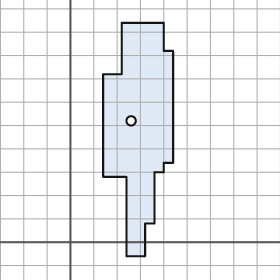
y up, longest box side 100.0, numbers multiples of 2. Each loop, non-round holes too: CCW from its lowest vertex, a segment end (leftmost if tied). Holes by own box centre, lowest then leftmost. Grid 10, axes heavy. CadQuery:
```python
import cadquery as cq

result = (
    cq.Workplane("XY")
    .moveTo(24.0, -6.0)
    .lineTo(32.0, -6.0)
    .lineTo(32.0, 8.0)
    .lineTo(36.0, 8.0)
    .lineTo(36.0, 30.0)
    .lineTo(40.0, 30.0)
    .lineTo(40.0, 34.0)
    .lineTo(44.0, 34.0)
    .lineTo(44.0, 82.0)
    .lineTo(40.0, 82.0)
    .lineTo(40.0, 94.0)
    .lineTo(22.0, 94.0)
    .lineTo(22.0, 72.0)
    .lineTo(14.0, 72.0)
    .lineTo(14.0, 28.0)
    .lineTo(24.0, 28.0)
    .close()
    .moveTo(26.0, 52.0)
    .circle(2.0)
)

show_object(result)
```